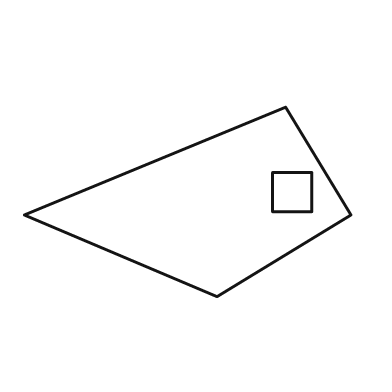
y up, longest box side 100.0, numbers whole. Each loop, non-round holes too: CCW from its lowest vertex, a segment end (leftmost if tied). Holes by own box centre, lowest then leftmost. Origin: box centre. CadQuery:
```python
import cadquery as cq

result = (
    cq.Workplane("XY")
    .moveTo(9.0, -29.0)
    .lineTo(50.0, -4.0)
    .lineTo(30.0, 29.0)
    .lineTo(-50.0, -4.0)
    .close()
    .moveTo(26.0, -3.0)
    .lineTo(38.0, -3.0)
    .lineTo(38.0, 9.0)
    .lineTo(26.0, 9.0)
    .close()
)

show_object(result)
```